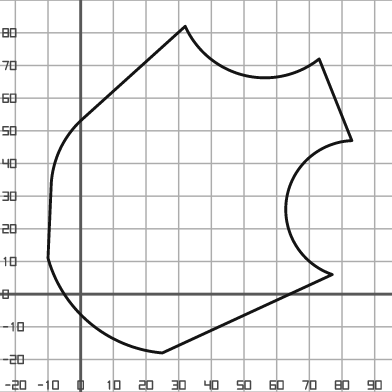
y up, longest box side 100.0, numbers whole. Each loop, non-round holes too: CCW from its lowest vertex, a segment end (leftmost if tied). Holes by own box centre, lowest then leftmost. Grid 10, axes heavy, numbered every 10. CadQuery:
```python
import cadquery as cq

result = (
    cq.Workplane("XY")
    .moveTo(25.0, -18.0)
    .lineTo(77.0, 6.0)
    .threePointArc((63.0, 29.0), (83.0, 47.0))
    .lineTo(73.0, 72.0)
    .threePointArc((50.0, 67.0), (32.0, 82.0))
    .lineTo(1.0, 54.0)
    .threePointArc((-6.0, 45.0), (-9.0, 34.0))
    .lineTo(-10.0, 11.0)
    .threePointArc((3.0, -9.0), (25.0, -18.0))
    .close()
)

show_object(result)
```